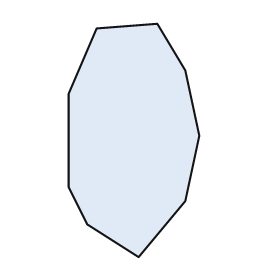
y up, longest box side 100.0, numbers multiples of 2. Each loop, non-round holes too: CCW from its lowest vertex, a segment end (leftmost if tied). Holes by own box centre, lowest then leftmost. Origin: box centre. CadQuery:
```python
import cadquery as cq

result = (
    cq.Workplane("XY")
    .moveTo(2.0, -50.0)
    .lineTo(22.0, -26.0)
    .lineTo(28.0, 2.0)
    .lineTo(22.0, 30.0)
    .lineTo(10.0, 50.0)
    .lineTo(-16.0, 48.0)
    .lineTo(-28.0, 20.0)
    .lineTo(-28.0, -20.0)
    .lineTo(-20.0, -36.0)
    .close()
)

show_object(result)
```